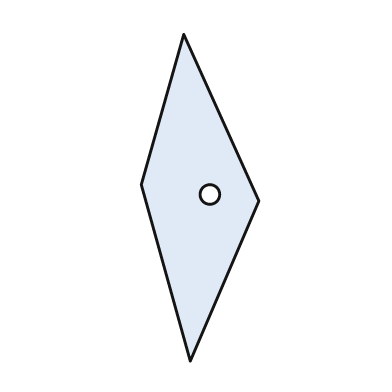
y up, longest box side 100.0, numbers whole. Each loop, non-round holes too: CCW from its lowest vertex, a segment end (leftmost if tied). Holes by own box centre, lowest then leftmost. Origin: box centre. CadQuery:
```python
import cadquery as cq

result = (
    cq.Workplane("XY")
    .moveTo(-3.0, -50.0)
    .lineTo(18.0, -1.0)
    .lineTo(-5.0, 50.0)
    .lineTo(-18.0, 4.0)
    .close()
    .moveTo(3.0, 1.0)
    .circle(3.0)
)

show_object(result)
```